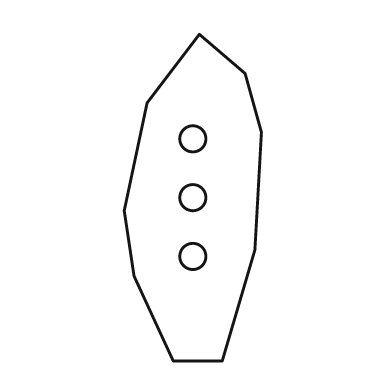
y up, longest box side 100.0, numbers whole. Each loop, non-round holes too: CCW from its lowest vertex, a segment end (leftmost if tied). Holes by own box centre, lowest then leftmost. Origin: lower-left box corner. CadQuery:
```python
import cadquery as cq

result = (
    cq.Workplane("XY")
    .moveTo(15.0, 0.0)
    .lineTo(30.0, 0.0)
    .lineTo(40.0, 34.0)
    .lineTo(42.0, 70.0)
    .lineTo(37.0, 88.0)
    .lineTo(23.0, 100.0)
    .lineTo(7.0, 79.0)
    .lineTo(0.0, 46.0)
    .lineTo(3.0, 26.0)
    .close()
    .moveTo(21.0, 32.0)
    .circle(4.0)
    .moveTo(21.0, 50.0)
    .circle(4.0)
    .moveTo(21.0, 68.0)
    .circle(4.0)
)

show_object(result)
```